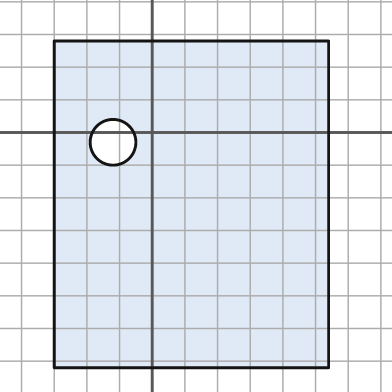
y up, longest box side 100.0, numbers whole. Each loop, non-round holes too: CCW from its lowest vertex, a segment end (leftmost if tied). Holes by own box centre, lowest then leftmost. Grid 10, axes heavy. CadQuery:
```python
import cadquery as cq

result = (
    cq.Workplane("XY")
    .moveTo(-30.0, -72.0)
    .lineTo(54.0, -72.0)
    .lineTo(54.0, 28.0)
    .lineTo(-30.0, 28.0)
    .close()
    .moveTo(-12.0, -3.0)
    .circle(7.0)
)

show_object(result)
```